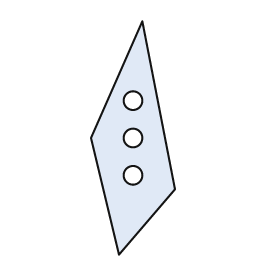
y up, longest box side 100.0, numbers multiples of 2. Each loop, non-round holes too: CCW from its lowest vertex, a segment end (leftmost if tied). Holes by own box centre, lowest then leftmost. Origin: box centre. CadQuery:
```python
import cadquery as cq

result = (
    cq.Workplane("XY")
    .moveTo(-6.0, -50.0)
    .lineTo(18.0, -22.0)
    .lineTo(4.0, 50.0)
    .lineTo(-18.0, 0.0)
    .close()
    .moveTo(0.0, -16.0)
    .circle(4.0)
    .moveTo(0.0, 0.0)
    .circle(4.0)
    .moveTo(0.0, 16.0)
    .circle(4.0)
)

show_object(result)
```